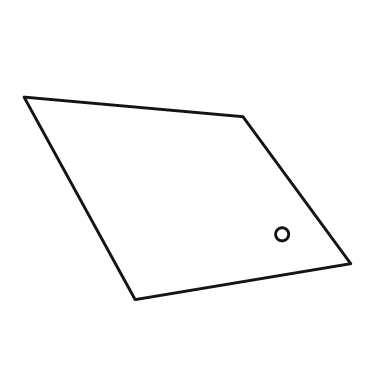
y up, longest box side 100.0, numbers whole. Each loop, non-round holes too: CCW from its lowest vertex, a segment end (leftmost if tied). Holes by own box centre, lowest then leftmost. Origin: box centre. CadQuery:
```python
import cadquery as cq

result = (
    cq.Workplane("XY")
    .moveTo(-16.0, -31.0)
    .lineTo(50.0, -20.0)
    .lineTo(17.0, 25.0)
    .lineTo(-50.0, 31.0)
    .close()
    .moveTo(29.0, -11.0)
    .circle(2.0)
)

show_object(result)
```